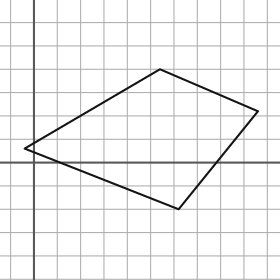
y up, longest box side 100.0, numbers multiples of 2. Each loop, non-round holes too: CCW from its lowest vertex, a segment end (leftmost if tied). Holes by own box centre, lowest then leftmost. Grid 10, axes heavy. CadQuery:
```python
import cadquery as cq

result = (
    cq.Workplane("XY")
    .moveTo(62.0, -20.0)
    .lineTo(96.0, 22.0)
    .lineTo(54.0, 40.0)
    .lineTo(-4.0, 6.0)
    .close()
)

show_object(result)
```